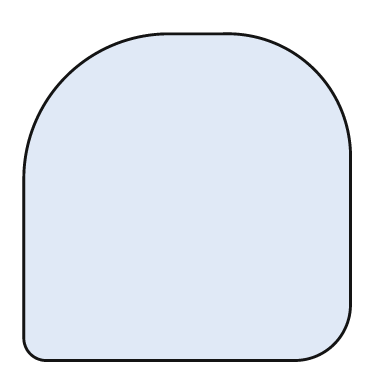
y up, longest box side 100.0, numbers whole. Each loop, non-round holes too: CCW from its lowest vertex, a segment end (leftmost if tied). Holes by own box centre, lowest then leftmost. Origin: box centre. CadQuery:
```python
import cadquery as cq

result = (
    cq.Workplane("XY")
    .moveTo(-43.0, -50.0)
    .lineTo(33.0, -50.0)
    .threePointArc((45.0, -45.0), (50.0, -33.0))
    .lineTo(50.0, 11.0)
    .threePointArc((39.0, 39.0), (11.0, 50.0))
    .lineTo(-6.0, 50.0)
    .threePointArc((-37.0, 37.0), (-50.0, 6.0))
    .lineTo(-50.0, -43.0)
    .threePointArc((-48.0, -48.0), (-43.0, -50.0))
    .close()
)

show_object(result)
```